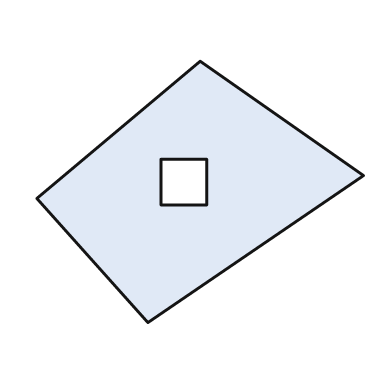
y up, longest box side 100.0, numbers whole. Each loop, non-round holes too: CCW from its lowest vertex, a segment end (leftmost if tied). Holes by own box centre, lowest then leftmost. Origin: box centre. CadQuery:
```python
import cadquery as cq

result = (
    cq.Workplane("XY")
    .moveTo(-16.0, -40.0)
    .lineTo(50.0, 5.0)
    .lineTo(0.0, 40.0)
    .lineTo(-50.0, -2.0)
    .close()
    .moveTo(-12.0, -4.0)
    .lineTo(2.0, -4.0)
    .lineTo(2.0, 10.0)
    .lineTo(-12.0, 10.0)
    .close()
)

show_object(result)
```